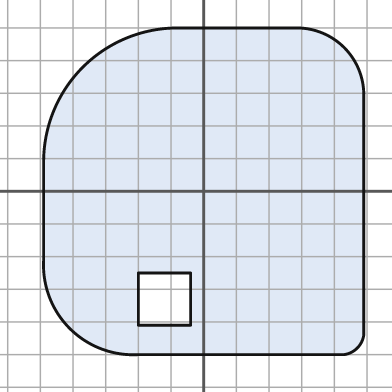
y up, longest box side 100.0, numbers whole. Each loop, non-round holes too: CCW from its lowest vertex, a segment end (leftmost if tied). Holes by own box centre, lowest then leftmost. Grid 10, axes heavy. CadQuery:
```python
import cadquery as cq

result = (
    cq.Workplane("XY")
    .moveTo(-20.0, -50.0)
    .lineTo(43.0, -50.0)
    .threePointArc((47.0, -48.0), (49.0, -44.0))
    .lineTo(49.0, 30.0)
    .threePointArc((43.0, 44.0), (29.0, 50.0))
    .lineTo(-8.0, 50.0)
    .threePointArc((-37.0, 38.0), (-49.0, 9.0))
    .lineTo(-49.0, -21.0)
    .threePointArc((-41.0, -42.0), (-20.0, -50.0))
    .close()
    .moveTo(-20.0, -41.0)
    .lineTo(-4.0, -41.0)
    .lineTo(-4.0, -25.0)
    .lineTo(-20.0, -25.0)
    .close()
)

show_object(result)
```